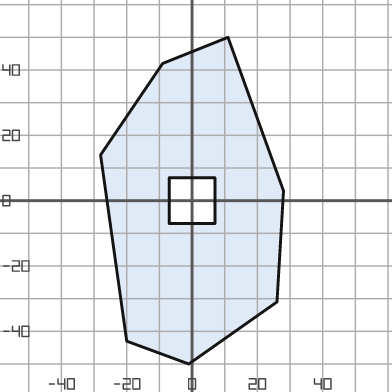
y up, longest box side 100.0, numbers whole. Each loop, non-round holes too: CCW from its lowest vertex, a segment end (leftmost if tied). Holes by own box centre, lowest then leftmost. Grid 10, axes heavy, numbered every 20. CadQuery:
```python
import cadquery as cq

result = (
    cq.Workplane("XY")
    .moveTo(-1.0, -50.0)
    .lineTo(26.0, -31.0)
    .lineTo(28.0, 3.0)
    .lineTo(11.0, 50.0)
    .lineTo(-9.0, 42.0)
    .lineTo(-28.0, 14.0)
    .lineTo(-20.0, -43.0)
    .close()
    .moveTo(-7.0, -7.0)
    .lineTo(7.0, -7.0)
    .lineTo(7.0, 7.0)
    .lineTo(-7.0, 7.0)
    .close()
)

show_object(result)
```